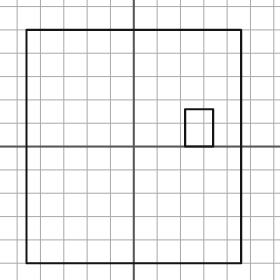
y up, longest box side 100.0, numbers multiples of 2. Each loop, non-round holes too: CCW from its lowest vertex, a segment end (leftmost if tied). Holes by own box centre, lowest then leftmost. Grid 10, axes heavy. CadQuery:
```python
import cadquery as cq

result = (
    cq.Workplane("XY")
    .moveTo(-46.0, -50.0)
    .lineTo(46.0, -50.0)
    .lineTo(46.0, 50.0)
    .lineTo(-46.0, 50.0)
    .close()
    .moveTo(22.0, 0.0)
    .lineTo(34.0, 0.0)
    .lineTo(34.0, 16.0)
    .lineTo(22.0, 16.0)
    .close()
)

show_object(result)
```